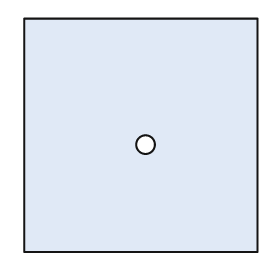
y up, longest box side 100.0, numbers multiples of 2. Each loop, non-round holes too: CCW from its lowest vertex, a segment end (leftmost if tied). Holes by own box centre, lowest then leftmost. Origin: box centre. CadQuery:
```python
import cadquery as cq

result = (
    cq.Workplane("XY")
    .moveTo(-50.0, -50.0)
    .lineTo(50.0, -50.0)
    .lineTo(50.0, 50.0)
    .lineTo(-50.0, 50.0)
    .close()
    .moveTo(2.0, -4.0)
    .circle(4.0)
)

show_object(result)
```